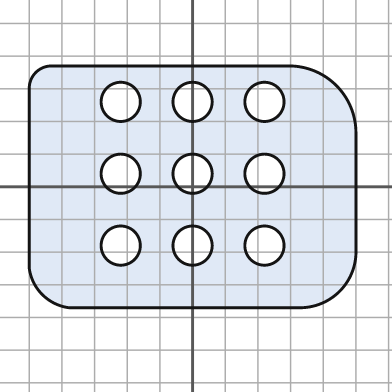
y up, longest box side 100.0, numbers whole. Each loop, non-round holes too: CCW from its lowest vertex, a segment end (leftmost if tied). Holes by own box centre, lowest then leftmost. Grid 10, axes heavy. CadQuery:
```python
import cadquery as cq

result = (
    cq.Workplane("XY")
    .moveTo(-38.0, -37.0)
    .lineTo(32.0, -37.0)
    .threePointArc((45.0, -32.0), (50.0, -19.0))
    .lineTo(50.0, 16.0)
    .threePointArc((44.0, 31.0), (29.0, 37.0))
    .lineTo(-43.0, 37.0)
    .threePointArc((-48.0, 35.0), (-50.0, 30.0))
    .lineTo(-50.0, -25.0)
    .threePointArc((-46.0, -33.0), (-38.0, -37.0))
    .close()
    .moveTo(-22.0, -18.0)
    .circle(6.0)
    .moveTo(0.0, -18.0)
    .circle(6.0)
    .moveTo(22.0, -18.0)
    .circle(6.0)
    .moveTo(-22.0, 4.0)
    .circle(6.0)
    .moveTo(0.0, 4.0)
    .circle(6.0)
    .moveTo(22.0, 4.0)
    .circle(6.0)
    .moveTo(-22.0, 26.0)
    .circle(6.0)
    .moveTo(0.0, 26.0)
    .circle(6.0)
    .moveTo(22.0, 26.0)
    .circle(6.0)
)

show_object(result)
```